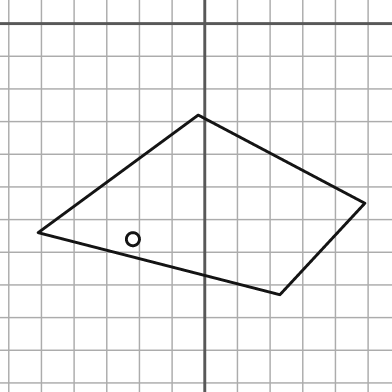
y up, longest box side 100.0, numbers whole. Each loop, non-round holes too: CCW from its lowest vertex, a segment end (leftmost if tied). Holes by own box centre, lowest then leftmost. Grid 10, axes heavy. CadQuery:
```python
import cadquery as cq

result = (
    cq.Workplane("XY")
    .moveTo(23.0, -83.0)
    .lineTo(49.0, -55.0)
    .lineTo(-2.0, -28.0)
    .lineTo(-51.0, -64.0)
    .close()
    .moveTo(-22.0, -66.0)
    .circle(2.0)
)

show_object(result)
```